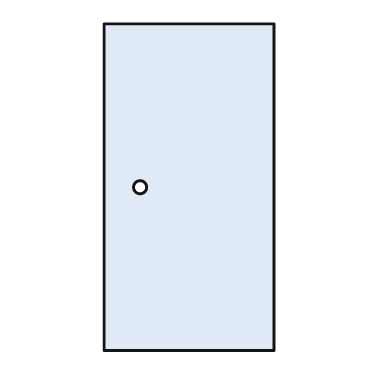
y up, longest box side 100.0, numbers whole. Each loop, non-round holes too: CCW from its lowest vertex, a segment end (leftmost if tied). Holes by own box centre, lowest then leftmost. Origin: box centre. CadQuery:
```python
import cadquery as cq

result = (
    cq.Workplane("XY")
    .moveTo(-26.0, -50.0)
    .lineTo(26.0, -50.0)
    .lineTo(26.0, 50.0)
    .lineTo(-26.0, 50.0)
    .close()
    .moveTo(-15.0, 0.0)
    .circle(2.0)
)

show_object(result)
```